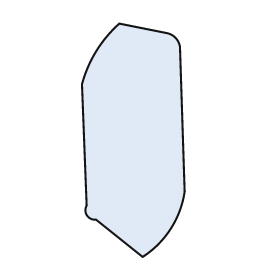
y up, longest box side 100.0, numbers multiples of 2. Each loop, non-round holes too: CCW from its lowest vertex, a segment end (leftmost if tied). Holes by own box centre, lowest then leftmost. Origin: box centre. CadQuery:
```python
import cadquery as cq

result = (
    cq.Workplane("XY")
    .moveTo(4.0, -50.0)
    .threePointArc((16.0, -38.0), (22.0, -22.0))
    .lineTo(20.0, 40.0)
    .threePointArc((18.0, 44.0), (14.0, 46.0))
    .lineTo(-6.0, 50.0)
    .threePointArc((-16.0, 38.0), (-22.0, 24.0))
    .lineTo(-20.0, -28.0)
    .threePointArc((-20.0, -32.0), (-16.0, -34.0))
    .close()
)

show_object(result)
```